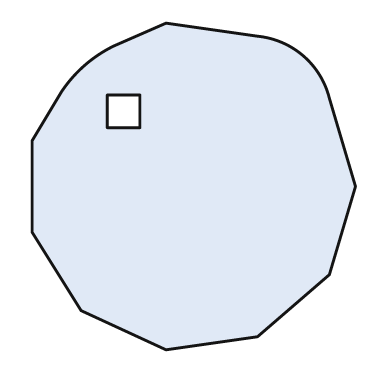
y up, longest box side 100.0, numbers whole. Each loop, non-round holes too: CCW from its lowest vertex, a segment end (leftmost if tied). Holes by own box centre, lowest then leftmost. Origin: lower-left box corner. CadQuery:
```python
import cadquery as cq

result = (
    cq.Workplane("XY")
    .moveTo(41.0, 0.0)
    .lineTo(69.0, 4.0)
    .lineTo(91.0, 23.0)
    .lineTo(99.0, 50.0)
    .lineTo(91.0, 77.0)
    .threePointArc((83.0, 90.0), (69.0, 96.0))
    .lineTo(41.0, 100.0)
    .lineTo(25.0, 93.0)
    .threePointArc((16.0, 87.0), (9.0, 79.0))
    .lineTo(0.0, 64.0)
    .lineTo(0.0, 36.0)
    .lineTo(15.0, 12.0)
    .close()
    .moveTo(23.0, 68.0)
    .lineTo(33.0, 68.0)
    .lineTo(33.0, 78.0)
    .lineTo(23.0, 78.0)
    .close()
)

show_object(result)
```